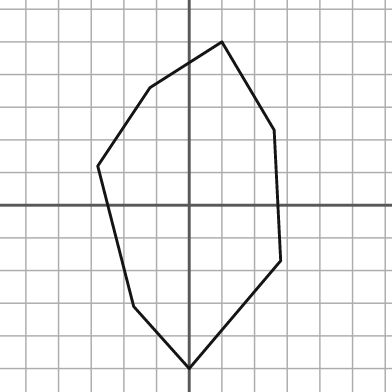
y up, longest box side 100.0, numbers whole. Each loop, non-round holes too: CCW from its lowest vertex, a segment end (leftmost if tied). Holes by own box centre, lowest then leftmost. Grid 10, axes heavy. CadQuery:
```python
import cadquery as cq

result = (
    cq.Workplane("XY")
    .moveTo(0.0, -50.0)
    .lineTo(28.0, -17.0)
    .lineTo(26.0, 23.0)
    .lineTo(10.0, 50.0)
    .lineTo(-12.0, 36.0)
    .lineTo(-28.0, 12.0)
    .lineTo(-17.0, -31.0)
    .close()
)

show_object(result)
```